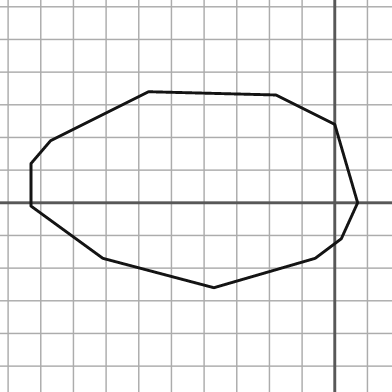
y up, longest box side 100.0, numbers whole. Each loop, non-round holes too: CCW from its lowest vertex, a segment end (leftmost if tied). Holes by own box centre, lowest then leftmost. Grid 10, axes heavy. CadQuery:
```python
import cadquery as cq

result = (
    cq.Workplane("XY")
    .moveTo(-37.0, -26.0)
    .lineTo(-6.0, -17.0)
    .lineTo(2.0, -11.0)
    .lineTo(7.0, 0.0)
    .lineTo(0.0, 24.0)
    .lineTo(-18.0, 33.0)
    .lineTo(-57.0, 34.0)
    .lineTo(-87.0, 19.0)
    .lineTo(-93.0, 12.0)
    .lineTo(-93.0, -1.0)
    .lineTo(-71.0, -17.0)
    .close()
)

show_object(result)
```